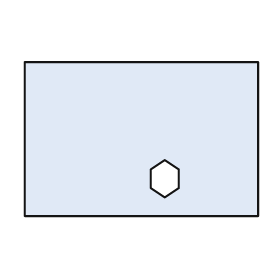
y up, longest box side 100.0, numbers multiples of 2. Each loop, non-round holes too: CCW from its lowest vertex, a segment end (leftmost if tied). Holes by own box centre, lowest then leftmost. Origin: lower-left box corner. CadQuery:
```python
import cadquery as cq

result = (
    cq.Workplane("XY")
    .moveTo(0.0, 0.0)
    .lineTo(100.0, 0.0)
    .lineTo(100.0, 66.0)
    .lineTo(0.0, 66.0)
    .close()
    .moveTo(60.0, 8.0)
    .lineTo(66.0, 12.0)
    .lineTo(66.0, 20.0)
    .lineTo(60.0, 24.0)
    .lineTo(54.0, 20.0)
    .lineTo(54.0, 12.0)
    .close()
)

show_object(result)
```